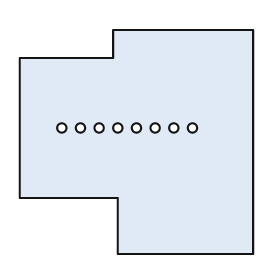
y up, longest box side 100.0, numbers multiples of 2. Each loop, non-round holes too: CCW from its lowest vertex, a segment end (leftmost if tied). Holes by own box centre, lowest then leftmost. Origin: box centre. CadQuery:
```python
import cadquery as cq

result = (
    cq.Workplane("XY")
    .moveTo(-8.0, -48.0)
    .lineTo(50.0, -48.0)
    .lineTo(50.0, 48.0)
    .lineTo(-10.0, 48.0)
    .lineTo(-10.0, 36.0)
    .lineTo(-50.0, 36.0)
    .lineTo(-50.0, -24.0)
    .lineTo(-8.0, -24.0)
    .close()
    .moveTo(-32.0, 6.0)
    .circle(2.0)
    .moveTo(-24.0, 6.0)
    .circle(2.0)
    .moveTo(-16.0, 6.0)
    .circle(2.0)
    .moveTo(-8.0, 6.0)
    .circle(2.0)
    .moveTo(0.0, 6.0)
    .circle(2.0)
    .moveTo(8.0, 6.0)
    .circle(2.0)
    .moveTo(16.0, 6.0)
    .circle(2.0)
    .moveTo(24.0, 6.0)
    .circle(2.0)
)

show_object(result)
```